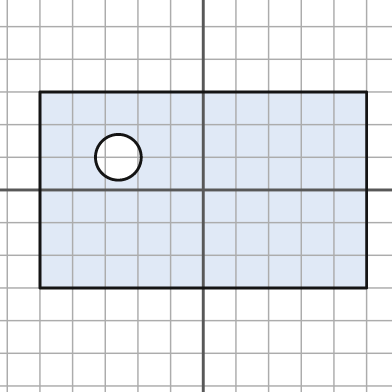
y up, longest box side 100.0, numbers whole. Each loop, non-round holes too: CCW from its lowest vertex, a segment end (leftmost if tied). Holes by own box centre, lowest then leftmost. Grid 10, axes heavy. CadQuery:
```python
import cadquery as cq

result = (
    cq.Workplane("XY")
    .moveTo(-50.0, -30.0)
    .lineTo(50.0, -30.0)
    .lineTo(50.0, 30.0)
    .lineTo(-50.0, 30.0)
    .close()
    .moveTo(-26.0, 10.0)
    .circle(7.0)
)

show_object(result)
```